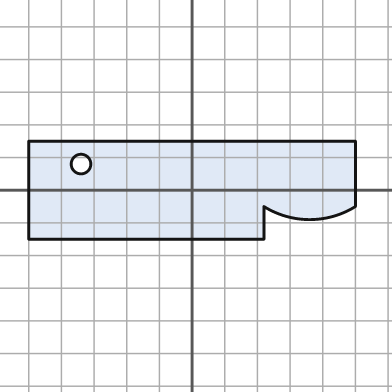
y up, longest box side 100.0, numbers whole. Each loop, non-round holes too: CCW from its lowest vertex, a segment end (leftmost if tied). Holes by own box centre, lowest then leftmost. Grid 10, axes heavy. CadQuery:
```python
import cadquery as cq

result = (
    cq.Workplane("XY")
    .moveTo(-50.0, -15.0)
    .lineTo(22.0, -15.0)
    .lineTo(22.0, -5.0)
    .threePointArc((36.0, -9.0), (50.0, -5.0))
    .lineTo(50.0, 15.0)
    .lineTo(-50.0, 15.0)
    .close()
    .moveTo(-34.0, 8.0)
    .circle(3.0)
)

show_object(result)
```